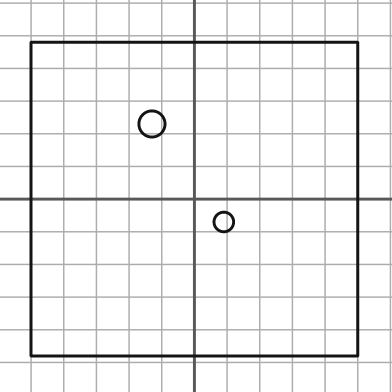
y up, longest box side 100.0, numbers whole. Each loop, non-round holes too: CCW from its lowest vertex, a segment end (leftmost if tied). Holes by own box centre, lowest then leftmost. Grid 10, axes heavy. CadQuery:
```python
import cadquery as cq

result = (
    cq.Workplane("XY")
    .moveTo(-50.0, -48.0)
    .lineTo(50.0, -48.0)
    .lineTo(50.0, 48.0)
    .lineTo(-50.0, 48.0)
    .close()
    .moveTo(9.0, -7.0)
    .circle(3.0)
    .moveTo(-13.0, 23.0)
    .circle(4.0)
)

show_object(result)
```